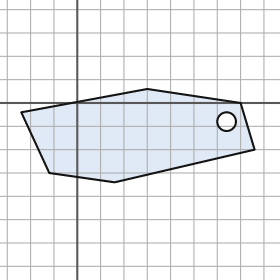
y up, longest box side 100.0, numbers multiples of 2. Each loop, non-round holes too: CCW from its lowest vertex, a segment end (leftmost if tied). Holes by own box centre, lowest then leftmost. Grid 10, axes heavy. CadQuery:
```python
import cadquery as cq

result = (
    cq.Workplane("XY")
    .moveTo(16.0, -34.0)
    .lineTo(76.0, -20.0)
    .lineTo(70.0, 0.0)
    .lineTo(30.0, 6.0)
    .lineTo(-24.0, -4.0)
    .lineTo(-12.0, -30.0)
    .close()
    .moveTo(64.0, -8.0)
    .circle(4.0)
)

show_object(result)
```